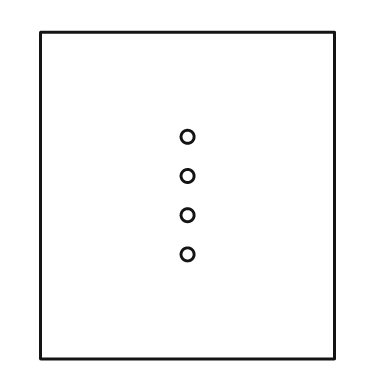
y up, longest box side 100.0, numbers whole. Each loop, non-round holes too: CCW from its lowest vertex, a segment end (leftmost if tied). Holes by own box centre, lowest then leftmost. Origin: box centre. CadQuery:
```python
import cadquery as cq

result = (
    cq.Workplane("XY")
    .moveTo(-45.0, -50.0)
    .lineTo(45.0, -50.0)
    .lineTo(45.0, 50.0)
    .lineTo(-45.0, 50.0)
    .close()
    .moveTo(0.0, -18.0)
    .circle(2.0)
    .moveTo(0.0, -6.0)
    .circle(2.0)
    .moveTo(0.0, 6.0)
    .circle(2.0)
    .moveTo(0.0, 18.0)
    .circle(2.0)
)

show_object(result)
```